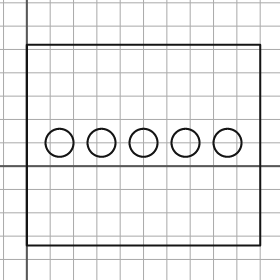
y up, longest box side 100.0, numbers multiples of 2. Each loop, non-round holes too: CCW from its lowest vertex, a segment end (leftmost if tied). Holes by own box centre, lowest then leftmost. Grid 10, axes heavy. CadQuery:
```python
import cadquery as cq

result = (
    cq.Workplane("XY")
    .moveTo(0.0, -34.0)
    .lineTo(100.0, -34.0)
    .lineTo(100.0, 52.0)
    .lineTo(0.0, 52.0)
    .close()
    .moveTo(14.0, 10.0)
    .circle(6.0)
    .moveTo(32.0, 10.0)
    .circle(6.0)
    .moveTo(50.0, 10.0)
    .circle(6.0)
    .moveTo(68.0, 10.0)
    .circle(6.0)
    .moveTo(86.0, 10.0)
    .circle(6.0)
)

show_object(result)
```